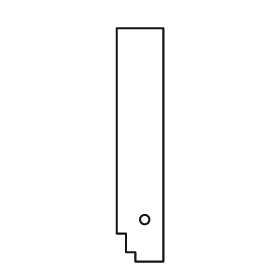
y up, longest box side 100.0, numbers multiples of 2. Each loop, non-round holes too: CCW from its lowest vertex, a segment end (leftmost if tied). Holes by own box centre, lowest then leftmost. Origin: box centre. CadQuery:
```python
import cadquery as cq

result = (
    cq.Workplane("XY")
    .moveTo(-2.0, -50.0)
    .lineTo(10.0, -50.0)
    .lineTo(10.0, 50.0)
    .lineTo(-10.0, 50.0)
    .lineTo(-10.0, -38.0)
    .lineTo(-6.0, -38.0)
    .lineTo(-6.0, -46.0)
    .lineTo(-2.0, -46.0)
    .close()
    .moveTo(2.0, -32.0)
    .circle(2.0)
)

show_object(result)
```